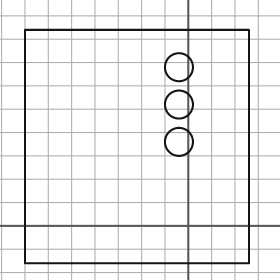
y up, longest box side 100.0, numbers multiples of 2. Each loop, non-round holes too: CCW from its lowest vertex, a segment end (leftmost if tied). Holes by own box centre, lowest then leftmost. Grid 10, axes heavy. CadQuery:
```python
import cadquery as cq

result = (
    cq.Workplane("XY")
    .moveTo(-70.0, -16.0)
    .lineTo(26.0, -16.0)
    .lineTo(26.0, 84.0)
    .lineTo(-70.0, 84.0)
    .close()
    .moveTo(-4.0, 36.0)
    .circle(6.0)
    .moveTo(-4.0, 52.0)
    .circle(6.0)
    .moveTo(-4.0, 68.0)
    .circle(6.0)
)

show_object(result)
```